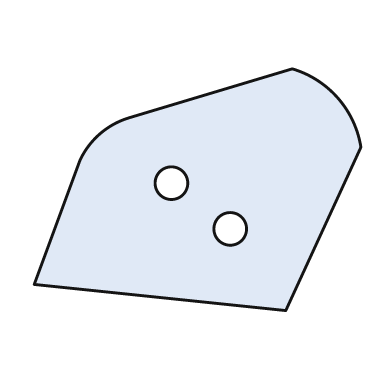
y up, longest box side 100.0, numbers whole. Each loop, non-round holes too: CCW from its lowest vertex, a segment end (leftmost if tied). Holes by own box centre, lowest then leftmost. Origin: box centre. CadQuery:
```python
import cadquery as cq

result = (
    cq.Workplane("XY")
    .moveTo(27.0, -37.0)
    .lineTo(50.0, 13.0)
    .threePointArc((43.0, 28.0), (29.0, 37.0))
    .lineTo(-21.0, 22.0)
    .threePointArc((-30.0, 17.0), (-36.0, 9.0))
    .lineTo(-50.0, -29.0)
    .close()
    .moveTo(10.0, -12.0)
    .circle(5.0)
    .moveTo(-8.0, 2.0)
    .circle(5.0)
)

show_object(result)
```